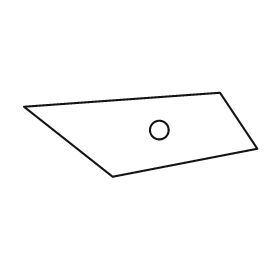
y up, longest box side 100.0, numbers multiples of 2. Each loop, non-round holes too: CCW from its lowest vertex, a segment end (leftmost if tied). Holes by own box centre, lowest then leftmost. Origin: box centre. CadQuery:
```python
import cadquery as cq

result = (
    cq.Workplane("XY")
    .moveTo(-12.0, -18.0)
    .lineTo(50.0, -6.0)
    .lineTo(34.0, 18.0)
    .lineTo(-50.0, 12.0)
    .close()
    .moveTo(8.0, 2.0)
    .circle(4.0)
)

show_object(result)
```